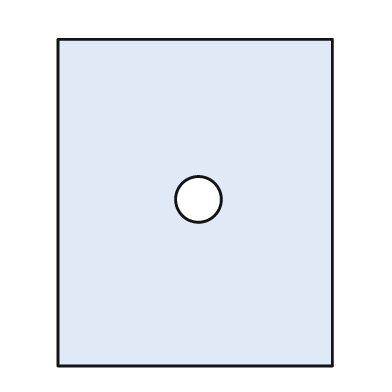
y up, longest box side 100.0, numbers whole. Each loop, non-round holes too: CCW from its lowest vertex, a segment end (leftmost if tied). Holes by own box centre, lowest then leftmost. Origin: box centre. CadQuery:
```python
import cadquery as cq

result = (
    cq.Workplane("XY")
    .moveTo(-42.0, -50.0)
    .lineTo(42.0, -50.0)
    .lineTo(42.0, 50.0)
    .lineTo(-42.0, 50.0)
    .close()
    .moveTo(1.0, 1.0)
    .circle(7.0)
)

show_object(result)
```